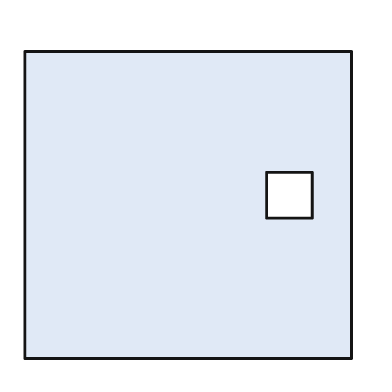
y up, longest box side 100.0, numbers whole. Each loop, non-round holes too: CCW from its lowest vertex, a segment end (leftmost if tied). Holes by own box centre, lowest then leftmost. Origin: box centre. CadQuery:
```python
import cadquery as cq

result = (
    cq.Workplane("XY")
    .moveTo(-50.0, -47.0)
    .lineTo(50.0, -47.0)
    .lineTo(50.0, 47.0)
    .lineTo(-50.0, 47.0)
    .close()
    .moveTo(24.0, -4.0)
    .lineTo(38.0, -4.0)
    .lineTo(38.0, 10.0)
    .lineTo(24.0, 10.0)
    .close()
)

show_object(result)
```